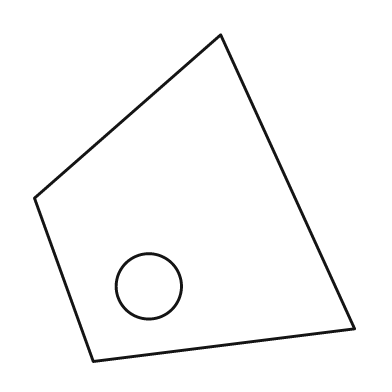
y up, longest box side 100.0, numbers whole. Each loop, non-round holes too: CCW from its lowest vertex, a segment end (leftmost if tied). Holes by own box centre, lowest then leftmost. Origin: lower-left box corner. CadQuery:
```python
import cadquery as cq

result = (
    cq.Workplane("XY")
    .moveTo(18.0, 0.0)
    .lineTo(98.0, 10.0)
    .lineTo(57.0, 100.0)
    .lineTo(0.0, 50.0)
    .close()
    .moveTo(35.0, 23.0)
    .circle(10.0)
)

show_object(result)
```